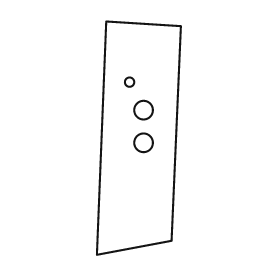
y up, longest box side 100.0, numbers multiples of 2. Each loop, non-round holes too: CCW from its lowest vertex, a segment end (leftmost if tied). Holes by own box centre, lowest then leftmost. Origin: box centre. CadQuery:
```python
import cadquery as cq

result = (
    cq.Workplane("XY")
    .moveTo(-18.0, -50.0)
    .lineTo(14.0, -44.0)
    .lineTo(18.0, 48.0)
    .lineTo(-14.0, 50.0)
    .close()
    .moveTo(2.0, -2.0)
    .circle(4.0)
    .moveTo(2.0, 12.0)
    .circle(4.0)
    .moveTo(-4.0, 24.0)
    .circle(2.0)
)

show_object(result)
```